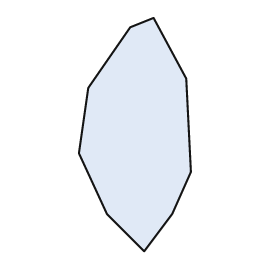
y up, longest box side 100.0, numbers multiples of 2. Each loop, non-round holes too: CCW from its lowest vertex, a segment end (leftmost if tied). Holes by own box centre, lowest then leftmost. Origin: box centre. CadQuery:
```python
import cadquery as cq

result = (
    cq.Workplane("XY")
    .moveTo(4.0, -50.0)
    .lineTo(16.0, -34.0)
    .lineTo(24.0, -16.0)
    .lineTo(22.0, 24.0)
    .lineTo(8.0, 50.0)
    .lineTo(-2.0, 46.0)
    .lineTo(-20.0, 20.0)
    .lineTo(-24.0, -8.0)
    .lineTo(-12.0, -34.0)
    .close()
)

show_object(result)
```